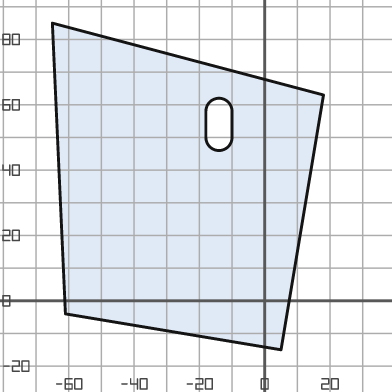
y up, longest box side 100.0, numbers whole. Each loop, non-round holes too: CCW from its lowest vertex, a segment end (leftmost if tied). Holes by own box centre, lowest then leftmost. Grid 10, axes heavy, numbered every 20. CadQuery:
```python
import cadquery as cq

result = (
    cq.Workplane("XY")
    .moveTo(5.0, -15.0)
    .lineTo(18.0, 63.0)
    .lineTo(-65.0, 85.0)
    .lineTo(-61.0, -4.0)
    .close()
    .moveTo(-18.0, 50.0)
    .threePointArc((-14.0, 46.0), (-10.0, 50.0))
    .lineTo(-10.0, 58.0)
    .threePointArc((-14.0, 62.0), (-18.0, 58.0))
    .close()
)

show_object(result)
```